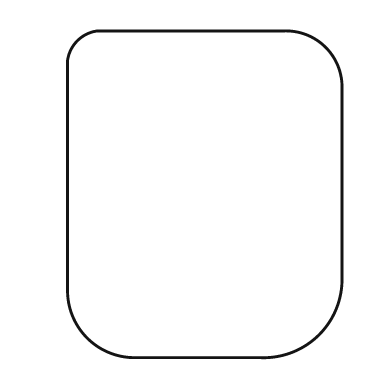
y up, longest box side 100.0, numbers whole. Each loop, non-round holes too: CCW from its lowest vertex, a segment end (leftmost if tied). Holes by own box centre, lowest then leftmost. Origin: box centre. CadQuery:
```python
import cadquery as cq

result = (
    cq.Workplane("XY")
    .moveTo(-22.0, -50.0)
    .lineTo(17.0, -50.0)
    .threePointArc((35.0, -43.0), (42.0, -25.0))
    .lineTo(42.0, 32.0)
    .threePointArc((37.0, 45.0), (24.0, 50.0))
    .lineTo(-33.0, 50.0)
    .threePointArc((-39.0, 47.0), (-42.0, 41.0))
    .lineTo(-42.0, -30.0)
    .threePointArc((-36.0, -44.0), (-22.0, -50.0))
    .close()
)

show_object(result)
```